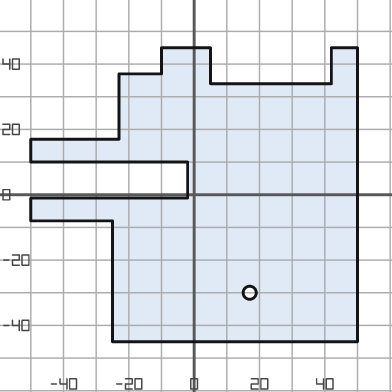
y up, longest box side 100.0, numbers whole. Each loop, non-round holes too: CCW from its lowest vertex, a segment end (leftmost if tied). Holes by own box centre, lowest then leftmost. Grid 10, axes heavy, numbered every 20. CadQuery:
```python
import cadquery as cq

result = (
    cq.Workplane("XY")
    .moveTo(-25.0, -45.0)
    .lineTo(50.0, -45.0)
    .lineTo(50.0, 45.0)
    .lineTo(42.0, 45.0)
    .lineTo(42.0, 34.0)
    .lineTo(5.0, 34.0)
    .lineTo(5.0, 45.0)
    .lineTo(-10.0, 45.0)
    .lineTo(-10.0, 37.0)
    .lineTo(-23.0, 37.0)
    .lineTo(-23.0, 17.0)
    .lineTo(-50.0, 17.0)
    .lineTo(-50.0, 10.0)
    .lineTo(-2.0, 10.0)
    .lineTo(-2.0, -1.0)
    .lineTo(-50.0, -1.0)
    .lineTo(-50.0, -8.0)
    .lineTo(-25.0, -8.0)
    .close()
    .moveTo(17.0, -30.0)
    .circle(2.0)
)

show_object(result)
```